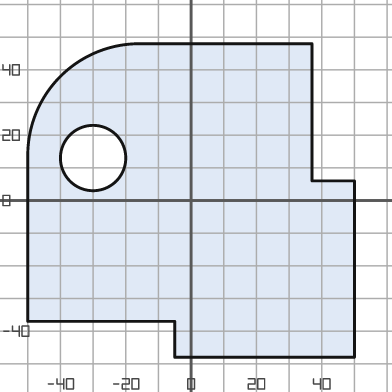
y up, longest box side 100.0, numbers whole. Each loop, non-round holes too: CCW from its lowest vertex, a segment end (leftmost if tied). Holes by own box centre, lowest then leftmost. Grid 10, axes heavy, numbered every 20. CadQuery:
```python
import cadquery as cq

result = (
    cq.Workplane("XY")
    .moveTo(-5.0, -48.0)
    .lineTo(50.0, -48.0)
    .lineTo(50.0, 6.0)
    .lineTo(37.0, 6.0)
    .lineTo(37.0, 48.0)
    .lineTo(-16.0, 48.0)
    .threePointArc((-40.0, 38.0), (-50.0, 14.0))
    .lineTo(-50.0, -37.0)
    .lineTo(-5.0, -37.0)
    .close()
    .moveTo(-30.0, 13.0)
    .circle(10.0)
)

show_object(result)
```